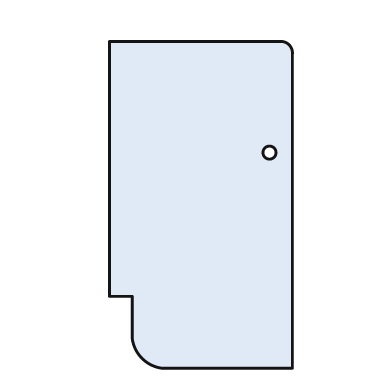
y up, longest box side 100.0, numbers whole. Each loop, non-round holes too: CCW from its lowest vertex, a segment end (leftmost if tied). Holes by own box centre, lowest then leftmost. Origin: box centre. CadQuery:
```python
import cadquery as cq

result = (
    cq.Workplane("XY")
    .moveTo(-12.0, -50.0)
    .lineTo(28.0, -50.0)
    .lineTo(28.0, 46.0)
    .threePointArc((27.0, 49.0), (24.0, 50.0))
    .lineTo(-28.0, 50.0)
    .lineTo(-28.0, -28.0)
    .lineTo(-21.0, -28.0)
    .lineTo(-21.0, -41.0)
    .threePointArc((-18.0, -47.0), (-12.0, -50.0))
    .close()
    .moveTo(21.0, 16.0)
    .circle(2.0)
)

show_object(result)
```